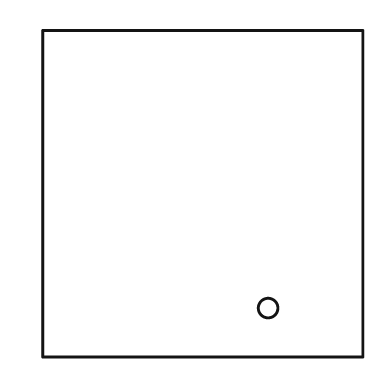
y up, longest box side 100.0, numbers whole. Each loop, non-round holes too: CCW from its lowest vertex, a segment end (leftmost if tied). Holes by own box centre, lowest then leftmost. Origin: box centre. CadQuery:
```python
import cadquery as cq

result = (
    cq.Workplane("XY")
    .moveTo(-49.0, -50.0)
    .lineTo(49.0, -50.0)
    .lineTo(49.0, 50.0)
    .lineTo(-49.0, 50.0)
    .close()
    .moveTo(20.0, -35.0)
    .circle(3.0)
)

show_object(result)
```